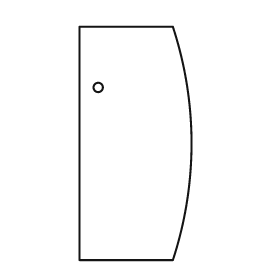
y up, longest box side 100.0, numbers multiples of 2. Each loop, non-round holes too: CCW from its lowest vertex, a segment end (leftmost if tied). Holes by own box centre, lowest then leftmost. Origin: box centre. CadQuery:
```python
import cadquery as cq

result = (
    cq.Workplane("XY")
    .moveTo(-24.0, -50.0)
    .lineTo(16.0, -50.0)
    .threePointArc((24.0, 0.0), (16.0, 50.0))
    .lineTo(-24.0, 50.0)
    .close()
    .moveTo(-16.0, 24.0)
    .circle(2.0)
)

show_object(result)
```